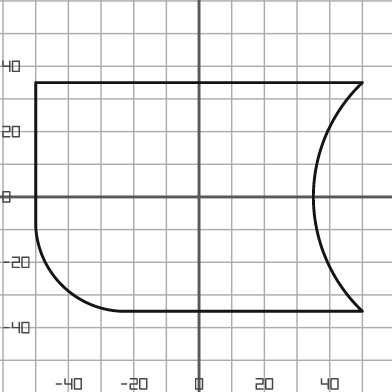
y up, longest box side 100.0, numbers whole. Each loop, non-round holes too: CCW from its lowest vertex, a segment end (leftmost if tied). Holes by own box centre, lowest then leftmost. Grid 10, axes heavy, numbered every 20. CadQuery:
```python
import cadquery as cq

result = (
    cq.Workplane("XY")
    .moveTo(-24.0, -35.0)
    .lineTo(50.0, -35.0)
    .threePointArc((35.0, 0.0), (50.0, 35.0))
    .lineTo(-50.0, 35.0)
    .lineTo(-50.0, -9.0)
    .threePointArc((-42.0, -27.0), (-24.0, -35.0))
    .close()
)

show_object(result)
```